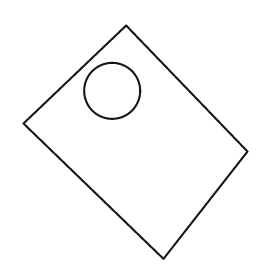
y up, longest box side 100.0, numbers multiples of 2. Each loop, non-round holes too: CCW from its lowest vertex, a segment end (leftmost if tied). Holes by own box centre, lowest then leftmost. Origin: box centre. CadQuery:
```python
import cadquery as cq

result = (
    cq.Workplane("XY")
    .moveTo(12.0, -50.0)
    .lineTo(48.0, -4.0)
    .lineTo(-4.0, 50.0)
    .lineTo(-48.0, 8.0)
    .close()
    .moveTo(-10.0, 22.0)
    .circle(12.0)
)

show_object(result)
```